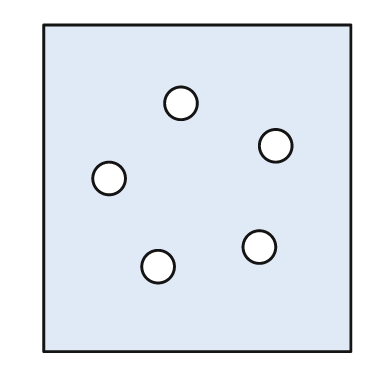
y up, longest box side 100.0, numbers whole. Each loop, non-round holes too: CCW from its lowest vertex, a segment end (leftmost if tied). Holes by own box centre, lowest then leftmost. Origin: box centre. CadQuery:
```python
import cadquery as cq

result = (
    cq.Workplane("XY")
    .moveTo(-47.0, -50.0)
    .lineTo(47.0, -50.0)
    .lineTo(47.0, 50.0)
    .lineTo(-47.0, 50.0)
    .close()
    .moveTo(-12.0, -24.0)
    .circle(5.0)
    .moveTo(19.0, -18.0)
    .circle(5.0)
    .moveTo(-27.0, 3.0)
    .circle(5.0)
    .moveTo(24.0, 13.0)
    .circle(5.0)
    .moveTo(-5.0, 26.0)
    .circle(5.0)
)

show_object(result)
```